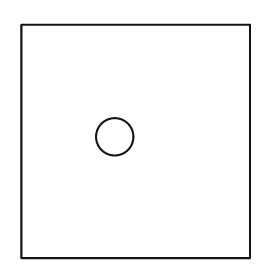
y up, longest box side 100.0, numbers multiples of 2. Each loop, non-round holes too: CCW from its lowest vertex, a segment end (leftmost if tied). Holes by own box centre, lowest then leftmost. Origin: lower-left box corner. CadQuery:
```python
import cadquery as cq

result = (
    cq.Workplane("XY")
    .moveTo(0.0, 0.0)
    .lineTo(98.0, 0.0)
    .lineTo(98.0, 100.0)
    .lineTo(0.0, 100.0)
    .close()
    .moveTo(40.0, 52.0)
    .circle(8.0)
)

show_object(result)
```